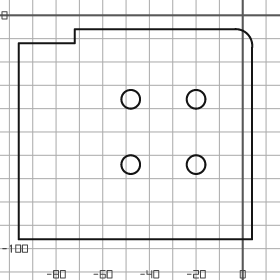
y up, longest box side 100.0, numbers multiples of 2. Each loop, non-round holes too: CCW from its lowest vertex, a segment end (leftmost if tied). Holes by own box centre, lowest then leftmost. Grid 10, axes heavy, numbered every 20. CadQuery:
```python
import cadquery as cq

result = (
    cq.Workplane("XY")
    .moveTo(-96.0, -96.0)
    .lineTo(4.0, -96.0)
    .lineTo(4.0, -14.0)
    .threePointArc((2.0, -8.0), (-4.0, -6.0))
    .lineTo(-72.0, -6.0)
    .lineTo(-72.0, -12.0)
    .lineTo(-96.0, -12.0)
    .close()
    .moveTo(-48.0, -64.0)
    .circle(4.0)
    .moveTo(-20.0, -64.0)
    .circle(4.0)
    .moveTo(-48.0, -36.0)
    .circle(4.0)
    .moveTo(-20.0, -36.0)
    .circle(4.0)
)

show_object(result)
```